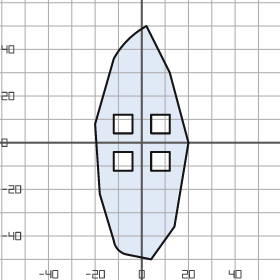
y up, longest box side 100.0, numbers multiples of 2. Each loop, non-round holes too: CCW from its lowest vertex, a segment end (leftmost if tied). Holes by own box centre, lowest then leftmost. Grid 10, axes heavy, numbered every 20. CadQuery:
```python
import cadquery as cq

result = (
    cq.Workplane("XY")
    .moveTo(4.0, -50.0)
    .lineTo(14.0, -36.0)
    .lineTo(20.0, 0.0)
    .lineTo(12.0, 30.0)
    .lineTo(2.0, 50.0)
    .threePointArc((-6.0, 44.0), (-12.0, 36.0))
    .lineTo(-20.0, 8.0)
    .lineTo(-18.0, -22.0)
    .lineTo(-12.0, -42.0)
    .threePointArc((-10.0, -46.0), (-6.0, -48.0))
    .close()
    .moveTo(-12.0, -12.0)
    .lineTo(-4.0, -12.0)
    .lineTo(-4.0, -4.0)
    .lineTo(-12.0, -4.0)
    .close()
    .moveTo(4.0, -12.0)
    .lineTo(12.0, -12.0)
    .lineTo(12.0, -4.0)
    .lineTo(4.0, -4.0)
    .close()
    .moveTo(-12.0, 4.0)
    .lineTo(-4.0, 4.0)
    .lineTo(-4.0, 12.0)
    .lineTo(-12.0, 12.0)
    .close()
    .moveTo(4.0, 4.0)
    .lineTo(12.0, 4.0)
    .lineTo(12.0, 12.0)
    .lineTo(4.0, 12.0)
    .close()
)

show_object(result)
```